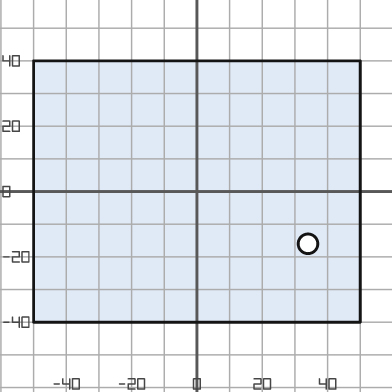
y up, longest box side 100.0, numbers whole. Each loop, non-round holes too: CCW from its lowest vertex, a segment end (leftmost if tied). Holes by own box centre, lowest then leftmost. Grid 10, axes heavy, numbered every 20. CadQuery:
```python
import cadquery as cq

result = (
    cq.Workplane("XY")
    .moveTo(-50.0, -40.0)
    .lineTo(50.0, -40.0)
    .lineTo(50.0, 40.0)
    .lineTo(-50.0, 40.0)
    .close()
    .moveTo(34.0, -16.0)
    .circle(3.0)
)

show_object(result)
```